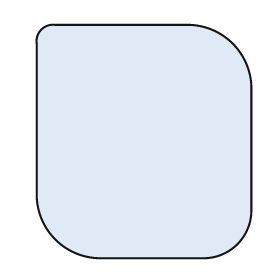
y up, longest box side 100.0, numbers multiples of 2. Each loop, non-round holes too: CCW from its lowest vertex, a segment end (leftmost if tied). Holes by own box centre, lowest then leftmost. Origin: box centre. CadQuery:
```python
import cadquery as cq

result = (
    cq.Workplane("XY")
    .moveTo(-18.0, -50.0)
    .lineTo(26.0, -50.0)
    .threePointArc((40.0, -44.0), (46.0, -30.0))
    .lineTo(46.0, 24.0)
    .threePointArc((38.0, 42.0), (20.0, 50.0))
    .lineTo(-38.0, 50.0)
    .threePointArc((-44.0, 48.0), (-46.0, 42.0))
    .lineTo(-46.0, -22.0)
    .threePointArc((-38.0, -42.0), (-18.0, -50.0))
    .close()
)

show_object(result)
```